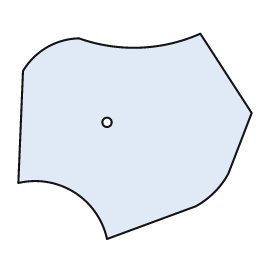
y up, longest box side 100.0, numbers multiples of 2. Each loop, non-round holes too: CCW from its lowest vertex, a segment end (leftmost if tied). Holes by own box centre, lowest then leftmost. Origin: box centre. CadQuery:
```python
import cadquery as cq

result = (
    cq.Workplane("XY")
    .moveTo(-12.0, -44.0)
    .lineTo(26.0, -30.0)
    .threePointArc((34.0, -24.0), (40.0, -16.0))
    .lineTo(50.0, 10.0)
    .lineTo(28.0, 44.0)
    .threePointArc((2.0, 38.0), (-24.0, 42.0))
    .threePointArc((-38.0, 38.0), (-48.0, 28.0))
    .lineTo(-50.0, -20.0)
    .threePointArc((-26.0, -24.0), (-12.0, -44.0))
    .close()
    .moveTo(-12.0, 6.0)
    .circle(2.0)
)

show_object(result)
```